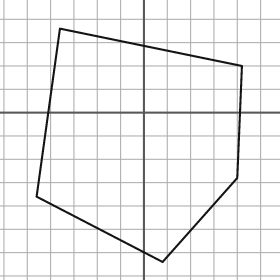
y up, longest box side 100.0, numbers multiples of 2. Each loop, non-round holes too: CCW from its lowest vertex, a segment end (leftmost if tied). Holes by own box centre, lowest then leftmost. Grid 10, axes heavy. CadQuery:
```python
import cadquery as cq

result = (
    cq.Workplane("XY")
    .moveTo(8.0, -64.0)
    .lineTo(40.0, -28.0)
    .lineTo(42.0, 20.0)
    .lineTo(-36.0, 36.0)
    .lineTo(-46.0, -36.0)
    .close()
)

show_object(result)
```